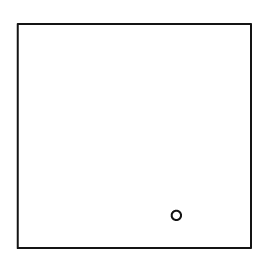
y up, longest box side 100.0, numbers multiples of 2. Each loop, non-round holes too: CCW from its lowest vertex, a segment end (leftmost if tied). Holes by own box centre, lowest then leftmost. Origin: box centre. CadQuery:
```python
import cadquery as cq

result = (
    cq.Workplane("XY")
    .moveTo(-50.0, -48.0)
    .lineTo(50.0, -48.0)
    .lineTo(50.0, 48.0)
    .lineTo(-50.0, 48.0)
    .close()
    .moveTo(18.0, -34.0)
    .circle(2.0)
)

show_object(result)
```